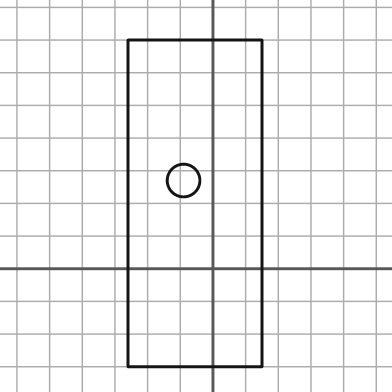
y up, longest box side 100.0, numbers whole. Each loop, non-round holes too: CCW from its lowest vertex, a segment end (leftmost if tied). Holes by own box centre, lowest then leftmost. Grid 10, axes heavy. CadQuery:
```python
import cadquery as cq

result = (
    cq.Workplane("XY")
    .moveTo(-26.0, -30.0)
    .lineTo(15.0, -30.0)
    .lineTo(15.0, 70.0)
    .lineTo(-26.0, 70.0)
    .close()
    .moveTo(-9.0, 27.0)
    .circle(5.0)
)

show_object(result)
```